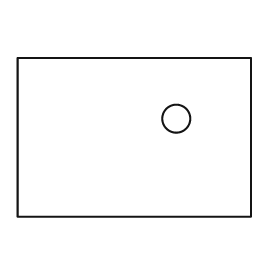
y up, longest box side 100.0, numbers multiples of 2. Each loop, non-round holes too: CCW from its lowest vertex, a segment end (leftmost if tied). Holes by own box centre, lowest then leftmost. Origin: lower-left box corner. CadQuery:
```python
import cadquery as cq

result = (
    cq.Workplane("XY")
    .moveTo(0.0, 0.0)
    .lineTo(100.0, 0.0)
    .lineTo(100.0, 68.0)
    .lineTo(0.0, 68.0)
    .close()
    .moveTo(68.0, 42.0)
    .circle(6.0)
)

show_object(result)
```